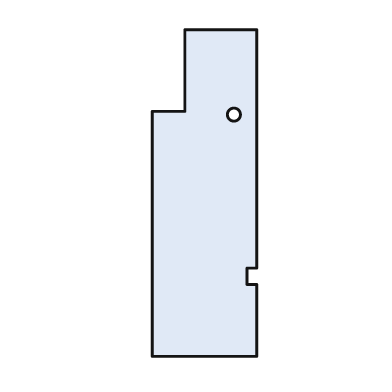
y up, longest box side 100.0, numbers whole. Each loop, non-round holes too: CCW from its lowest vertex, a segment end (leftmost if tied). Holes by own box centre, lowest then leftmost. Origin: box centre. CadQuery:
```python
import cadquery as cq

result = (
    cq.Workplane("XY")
    .moveTo(-16.0, -50.0)
    .lineTo(16.0, -50.0)
    .lineTo(16.0, -28.0)
    .lineTo(13.0, -28.0)
    .lineTo(13.0, -23.0)
    .lineTo(16.0, -23.0)
    .lineTo(16.0, 50.0)
    .lineTo(-6.0, 50.0)
    .lineTo(-6.0, 25.0)
    .lineTo(-16.0, 25.0)
    .close()
    .moveTo(9.0, 24.0)
    .circle(2.0)
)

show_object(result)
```